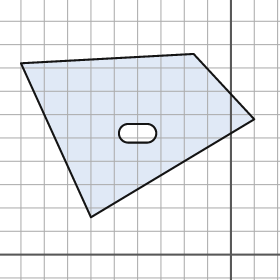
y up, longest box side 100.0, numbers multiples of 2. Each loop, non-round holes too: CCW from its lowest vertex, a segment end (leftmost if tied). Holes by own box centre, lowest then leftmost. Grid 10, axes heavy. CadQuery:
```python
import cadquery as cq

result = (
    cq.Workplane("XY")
    .moveTo(-60.0, 16.0)
    .lineTo(10.0, 58.0)
    .lineTo(-16.0, 86.0)
    .lineTo(-90.0, 82.0)
    .close()
    .moveTo(-44.0, 48.0)
    .lineTo(-36.0, 48.0)
    .threePointArc((-32.0, 52.0), (-36.0, 56.0))
    .lineTo(-44.0, 56.0)
    .threePointArc((-48.0, 52.0), (-44.0, 48.0))
    .close()
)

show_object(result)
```